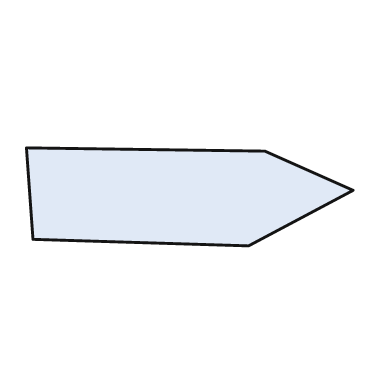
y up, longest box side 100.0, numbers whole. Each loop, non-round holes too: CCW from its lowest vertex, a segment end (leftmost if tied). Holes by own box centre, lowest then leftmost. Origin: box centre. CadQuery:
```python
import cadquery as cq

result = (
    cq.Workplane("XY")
    .moveTo(18.0, -15.0)
    .lineTo(50.0, 2.0)
    .lineTo(23.0, 14.0)
    .lineTo(-50.0, 15.0)
    .lineTo(-48.0, -13.0)
    .close()
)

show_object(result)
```